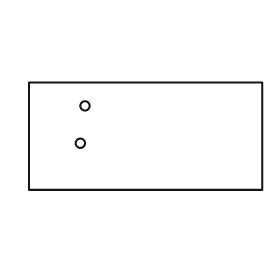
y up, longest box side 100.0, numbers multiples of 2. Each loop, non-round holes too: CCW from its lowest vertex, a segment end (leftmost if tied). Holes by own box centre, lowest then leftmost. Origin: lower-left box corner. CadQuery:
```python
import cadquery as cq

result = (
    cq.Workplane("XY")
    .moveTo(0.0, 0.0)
    .lineTo(100.0, 0.0)
    .lineTo(100.0, 46.0)
    .lineTo(0.0, 46.0)
    .close()
    .moveTo(22.0, 20.0)
    .circle(2.0)
    .moveTo(24.0, 36.0)
    .circle(2.0)
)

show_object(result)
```